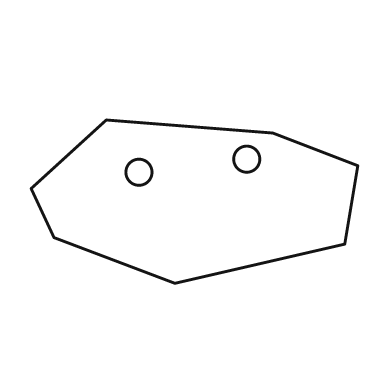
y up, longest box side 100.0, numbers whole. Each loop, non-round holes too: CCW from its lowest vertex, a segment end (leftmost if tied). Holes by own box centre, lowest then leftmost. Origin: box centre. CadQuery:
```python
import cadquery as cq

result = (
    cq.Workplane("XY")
    .moveTo(-6.0, -25.0)
    .lineTo(46.0, -13.0)
    .lineTo(50.0, 11.0)
    .lineTo(24.0, 21.0)
    .lineTo(-27.0, 25.0)
    .lineTo(-50.0, 4.0)
    .lineTo(-43.0, -11.0)
    .close()
    .moveTo(-17.0, 9.0)
    .circle(4.0)
    .moveTo(16.0, 13.0)
    .circle(4.0)
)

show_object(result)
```